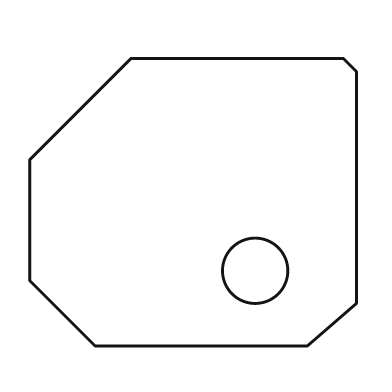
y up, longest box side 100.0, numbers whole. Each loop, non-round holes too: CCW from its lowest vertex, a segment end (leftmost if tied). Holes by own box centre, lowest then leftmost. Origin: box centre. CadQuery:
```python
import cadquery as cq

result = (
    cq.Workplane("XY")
    .moveTo(-30.0, -44.0)
    .lineTo(35.0, -44.0)
    .lineTo(50.0, -31.0)
    .lineTo(50.0, 40.0)
    .lineTo(46.0, 44.0)
    .lineTo(-19.0, 44.0)
    .lineTo(-50.0, 13.0)
    .lineTo(-50.0, -24.0)
    .close()
    .moveTo(19.0, -21.0)
    .circle(10.0)
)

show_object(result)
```